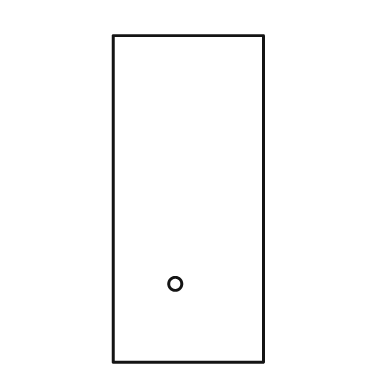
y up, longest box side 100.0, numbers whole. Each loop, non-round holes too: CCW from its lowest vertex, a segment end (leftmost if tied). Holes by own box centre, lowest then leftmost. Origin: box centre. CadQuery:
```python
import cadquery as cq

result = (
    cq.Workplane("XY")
    .moveTo(-23.0, -50.0)
    .lineTo(23.0, -50.0)
    .lineTo(23.0, 50.0)
    .lineTo(-23.0, 50.0)
    .close()
    .moveTo(-4.0, -26.0)
    .circle(2.0)
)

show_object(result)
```